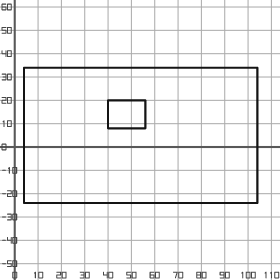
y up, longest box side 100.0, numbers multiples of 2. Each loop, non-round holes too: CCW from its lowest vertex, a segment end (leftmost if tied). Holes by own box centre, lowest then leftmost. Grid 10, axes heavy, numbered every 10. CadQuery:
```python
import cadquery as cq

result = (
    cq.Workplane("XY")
    .moveTo(4.0, -24.0)
    .lineTo(104.0, -24.0)
    .lineTo(104.0, 34.0)
    .lineTo(4.0, 34.0)
    .close()
    .moveTo(40.0, 8.0)
    .lineTo(56.0, 8.0)
    .lineTo(56.0, 20.0)
    .lineTo(40.0, 20.0)
    .close()
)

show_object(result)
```